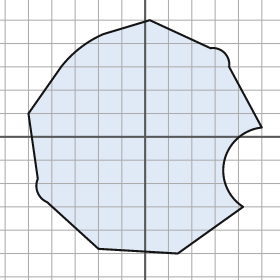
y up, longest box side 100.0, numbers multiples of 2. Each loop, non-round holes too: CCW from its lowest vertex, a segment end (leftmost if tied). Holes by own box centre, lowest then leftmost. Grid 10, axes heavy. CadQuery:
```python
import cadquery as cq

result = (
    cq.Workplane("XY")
    .moveTo(14.0, -50.0)
    .lineTo(42.0, -30.0)
    .threePointArc((34.0, -10.0), (50.0, 4.0))
    .lineTo(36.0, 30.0)
    .threePointArc((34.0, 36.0), (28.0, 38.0))
    .lineTo(2.0, 50.0)
    .lineTo(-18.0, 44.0)
    .threePointArc((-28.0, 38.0), (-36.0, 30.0))
    .lineTo(-50.0, 10.0)
    .lineTo(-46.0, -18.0)
    .threePointArc((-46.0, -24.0), (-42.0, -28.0))
    .lineTo(-20.0, -48.0)
    .close()
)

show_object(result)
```